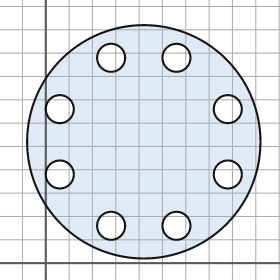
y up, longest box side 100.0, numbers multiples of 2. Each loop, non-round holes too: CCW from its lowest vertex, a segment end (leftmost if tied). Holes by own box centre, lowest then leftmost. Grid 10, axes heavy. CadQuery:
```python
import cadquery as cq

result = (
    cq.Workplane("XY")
    .moveTo(42.0, 52.0)
    .circle(50.0)
    .moveTo(28.0, 16.0)
    .circle(6.0)
    .moveTo(56.0, 16.0)
    .circle(6.0)
    .moveTo(6.0, 38.0)
    .circle(6.0)
    .moveTo(78.0, 38.0)
    .circle(6.0)
    .moveTo(6.0, 66.0)
    .circle(6.0)
    .moveTo(78.0, 66.0)
    .circle(6.0)
    .moveTo(28.0, 88.0)
    .circle(6.0)
    .moveTo(56.0, 88.0)
    .circle(6.0)
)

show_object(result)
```